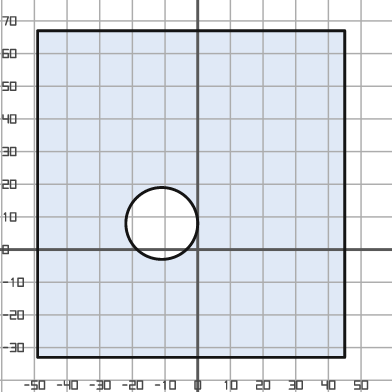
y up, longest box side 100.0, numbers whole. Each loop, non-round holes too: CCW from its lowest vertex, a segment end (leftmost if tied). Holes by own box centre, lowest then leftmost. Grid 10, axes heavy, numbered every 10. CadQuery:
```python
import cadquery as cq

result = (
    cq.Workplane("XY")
    .moveTo(-49.0, -33.0)
    .lineTo(45.0, -33.0)
    .lineTo(45.0, 67.0)
    .lineTo(-49.0, 67.0)
    .close()
    .moveTo(-11.0, 8.0)
    .circle(11.0)
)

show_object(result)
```